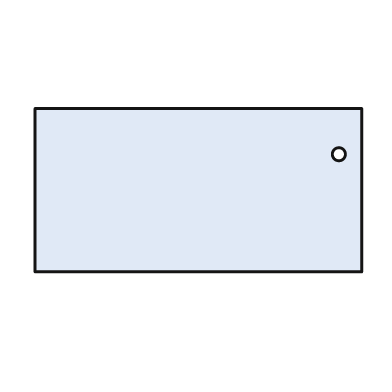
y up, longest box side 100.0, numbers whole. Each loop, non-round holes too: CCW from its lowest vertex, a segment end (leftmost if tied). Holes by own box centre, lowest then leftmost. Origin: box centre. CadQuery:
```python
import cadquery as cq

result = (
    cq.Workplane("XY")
    .moveTo(-50.0, -25.0)
    .lineTo(50.0, -25.0)
    .lineTo(50.0, 25.0)
    .lineTo(-50.0, 25.0)
    .close()
    .moveTo(43.0, 11.0)
    .circle(2.0)
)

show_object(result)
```